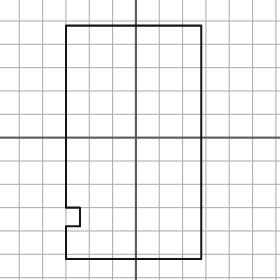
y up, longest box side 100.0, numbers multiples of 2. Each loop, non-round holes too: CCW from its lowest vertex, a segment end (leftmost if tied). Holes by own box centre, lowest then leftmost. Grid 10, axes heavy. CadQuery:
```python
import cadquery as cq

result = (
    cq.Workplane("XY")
    .moveTo(-30.0, -52.0)
    .lineTo(28.0, -52.0)
    .lineTo(28.0, 48.0)
    .lineTo(-30.0, 48.0)
    .lineTo(-30.0, -30.0)
    .lineTo(-24.0, -30.0)
    .lineTo(-24.0, -38.0)
    .lineTo(-30.0, -38.0)
    .close()
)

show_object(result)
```